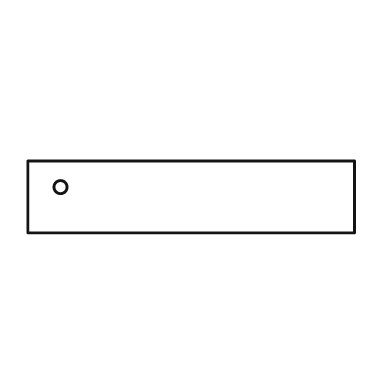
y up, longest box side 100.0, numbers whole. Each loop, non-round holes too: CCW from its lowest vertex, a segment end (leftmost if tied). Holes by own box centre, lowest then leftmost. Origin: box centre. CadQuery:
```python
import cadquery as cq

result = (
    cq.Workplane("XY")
    .moveTo(-50.0, -11.0)
    .lineTo(50.0, -11.0)
    .lineTo(50.0, 11.0)
    .lineTo(-50.0, 11.0)
    .close()
    .moveTo(-40.0, 3.0)
    .circle(2.0)
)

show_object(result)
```